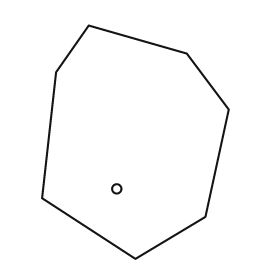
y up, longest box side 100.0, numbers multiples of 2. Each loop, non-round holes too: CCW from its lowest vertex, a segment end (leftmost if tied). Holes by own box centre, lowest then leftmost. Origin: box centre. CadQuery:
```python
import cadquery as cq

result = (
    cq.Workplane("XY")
    .moveTo(0.0, -50.0)
    .lineTo(30.0, -32.0)
    .lineTo(40.0, 14.0)
    .lineTo(22.0, 38.0)
    .lineTo(-20.0, 50.0)
    .lineTo(-34.0, 30.0)
    .lineTo(-40.0, -24.0)
    .close()
    .moveTo(-8.0, -20.0)
    .circle(2.0)
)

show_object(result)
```